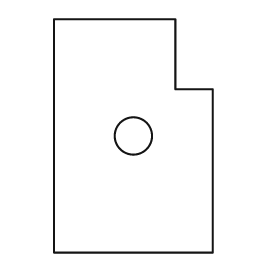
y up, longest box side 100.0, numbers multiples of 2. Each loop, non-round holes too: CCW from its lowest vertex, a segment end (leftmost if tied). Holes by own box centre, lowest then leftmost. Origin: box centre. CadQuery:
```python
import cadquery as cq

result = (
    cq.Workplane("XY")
    .moveTo(-34.0, -50.0)
    .lineTo(34.0, -50.0)
    .lineTo(34.0, 20.0)
    .lineTo(18.0, 20.0)
    .lineTo(18.0, 50.0)
    .lineTo(-34.0, 50.0)
    .close()
    .moveTo(0.0, 0.0)
    .circle(8.0)
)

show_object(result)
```